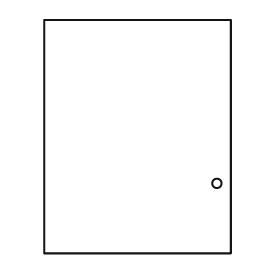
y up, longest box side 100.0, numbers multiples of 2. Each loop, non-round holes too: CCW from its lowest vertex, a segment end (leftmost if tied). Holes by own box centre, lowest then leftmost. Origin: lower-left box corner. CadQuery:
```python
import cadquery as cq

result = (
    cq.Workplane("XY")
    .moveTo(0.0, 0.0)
    .lineTo(80.0, 0.0)
    .lineTo(80.0, 100.0)
    .lineTo(0.0, 100.0)
    .close()
    .moveTo(74.0, 30.0)
    .circle(2.0)
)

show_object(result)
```